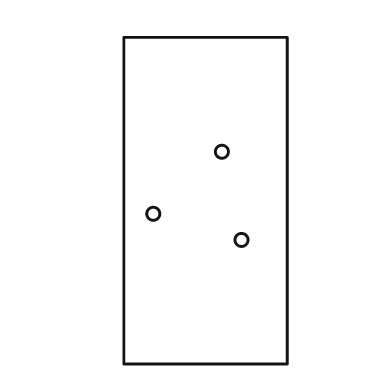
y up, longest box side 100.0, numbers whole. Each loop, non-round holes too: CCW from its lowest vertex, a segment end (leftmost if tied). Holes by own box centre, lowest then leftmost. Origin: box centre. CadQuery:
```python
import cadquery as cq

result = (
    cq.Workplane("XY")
    .moveTo(-25.0, -50.0)
    .lineTo(25.0, -50.0)
    .lineTo(25.0, 50.0)
    .lineTo(-25.0, 50.0)
    .close()
    .moveTo(11.0, -12.0)
    .circle(2.0)
    .moveTo(-16.0, -4.0)
    .circle(2.0)
    .moveTo(5.0, 15.0)
    .circle(2.0)
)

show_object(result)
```